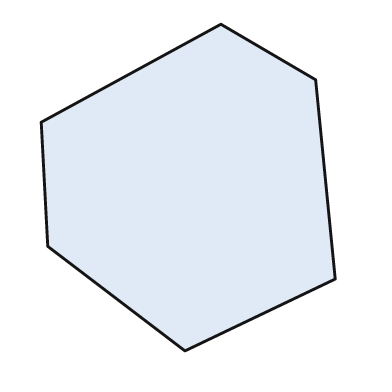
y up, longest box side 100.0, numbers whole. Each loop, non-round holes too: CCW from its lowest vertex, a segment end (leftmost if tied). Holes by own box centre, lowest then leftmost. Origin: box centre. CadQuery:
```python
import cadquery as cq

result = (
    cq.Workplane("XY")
    .moveTo(-1.0, -50.0)
    .lineTo(45.0, -28.0)
    .lineTo(39.0, 33.0)
    .lineTo(10.0, 50.0)
    .lineTo(-45.0, 20.0)
    .lineTo(-43.0, -18.0)
    .close()
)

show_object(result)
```